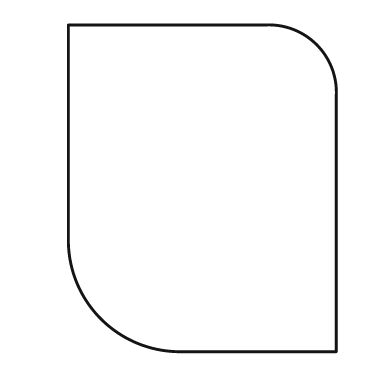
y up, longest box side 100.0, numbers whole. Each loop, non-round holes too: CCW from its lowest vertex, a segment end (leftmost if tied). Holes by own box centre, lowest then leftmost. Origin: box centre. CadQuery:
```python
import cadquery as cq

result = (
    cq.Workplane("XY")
    .moveTo(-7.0, -50.0)
    .lineTo(41.0, -50.0)
    .lineTo(41.0, 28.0)
    .threePointArc((35.0, 44.0), (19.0, 50.0))
    .lineTo(-41.0, 50.0)
    .lineTo(-41.0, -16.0)
    .threePointArc((-31.0, -40.0), (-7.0, -50.0))
    .close()
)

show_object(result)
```